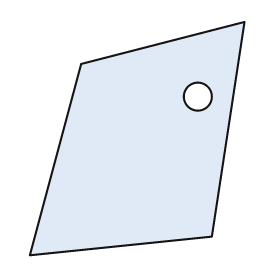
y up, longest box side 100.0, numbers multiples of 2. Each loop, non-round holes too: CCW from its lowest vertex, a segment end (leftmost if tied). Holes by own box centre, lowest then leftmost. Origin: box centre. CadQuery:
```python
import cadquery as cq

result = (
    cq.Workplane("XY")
    .moveTo(-46.0, -50.0)
    .lineTo(32.0, -42.0)
    .lineTo(46.0, 50.0)
    .lineTo(-24.0, 32.0)
    .close()
    .moveTo(26.0, 18.0)
    .circle(6.0)
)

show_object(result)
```